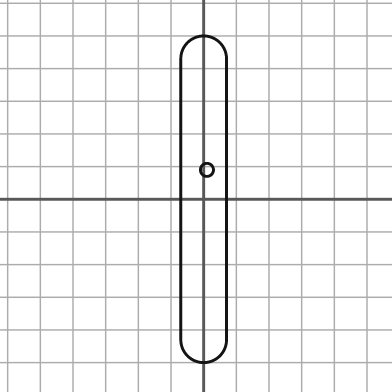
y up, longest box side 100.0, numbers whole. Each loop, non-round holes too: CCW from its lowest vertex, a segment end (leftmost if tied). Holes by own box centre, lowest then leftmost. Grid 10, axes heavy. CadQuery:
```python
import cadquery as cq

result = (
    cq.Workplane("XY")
    .moveTo(-7.0, -43.0)
    .threePointArc((0.0, -50.0), (7.0, -43.0))
    .lineTo(7.0, 43.0)
    .threePointArc((0.0, 50.0), (-7.0, 43.0))
    .close()
    .moveTo(1.0, 9.0)
    .circle(2.0)
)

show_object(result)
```